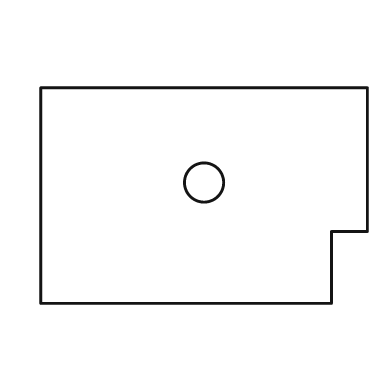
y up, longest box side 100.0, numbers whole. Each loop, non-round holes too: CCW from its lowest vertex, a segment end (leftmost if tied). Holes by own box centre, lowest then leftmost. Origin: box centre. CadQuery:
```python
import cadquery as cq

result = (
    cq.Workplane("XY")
    .moveTo(-50.0, -33.0)
    .lineTo(39.0, -33.0)
    .lineTo(39.0, -11.0)
    .lineTo(50.0, -11.0)
    .lineTo(50.0, 33.0)
    .lineTo(-50.0, 33.0)
    .close()
    .moveTo(0.0, 4.0)
    .circle(6.0)
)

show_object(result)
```